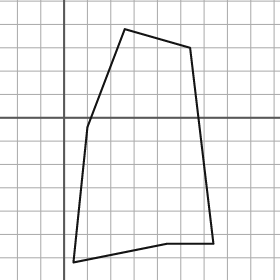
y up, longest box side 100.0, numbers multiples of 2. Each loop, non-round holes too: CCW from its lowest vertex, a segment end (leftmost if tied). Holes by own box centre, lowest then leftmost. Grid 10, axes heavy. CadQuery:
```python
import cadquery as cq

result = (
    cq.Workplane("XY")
    .moveTo(4.0, -62.0)
    .lineTo(44.0, -54.0)
    .lineTo(64.0, -54.0)
    .lineTo(54.0, 30.0)
    .lineTo(26.0, 38.0)
    .lineTo(10.0, -4.0)
    .close()
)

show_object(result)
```